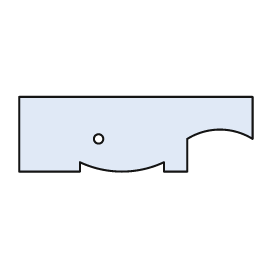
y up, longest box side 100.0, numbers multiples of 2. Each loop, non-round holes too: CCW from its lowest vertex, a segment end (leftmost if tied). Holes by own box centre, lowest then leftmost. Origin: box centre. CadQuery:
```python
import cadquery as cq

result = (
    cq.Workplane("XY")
    .moveTo(-50.0, -16.0)
    .lineTo(-24.0, -16.0)
    .lineTo(-24.0, -12.0)
    .threePointArc((-6.0, -16.0), (12.0, -12.0))
    .lineTo(12.0, -16.0)
    .lineTo(22.0, -16.0)
    .lineTo(22.0, -2.0)
    .threePointArc((36.0, 2.0), (50.0, -2.0))
    .lineTo(50.0, 16.0)
    .lineTo(-50.0, 16.0)
    .close()
    .moveTo(-16.0, -2.0)
    .circle(2.0)
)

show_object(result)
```